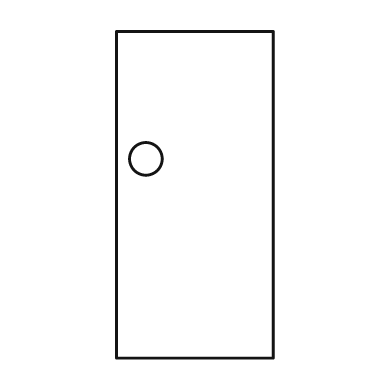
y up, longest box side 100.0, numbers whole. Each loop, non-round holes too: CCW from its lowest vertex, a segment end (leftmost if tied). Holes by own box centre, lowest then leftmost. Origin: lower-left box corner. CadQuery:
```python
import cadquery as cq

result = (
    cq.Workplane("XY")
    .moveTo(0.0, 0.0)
    .lineTo(48.0, 0.0)
    .lineTo(48.0, 100.0)
    .lineTo(0.0, 100.0)
    .close()
    .moveTo(9.0, 61.0)
    .circle(5.0)
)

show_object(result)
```